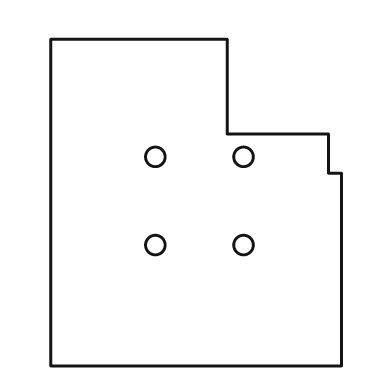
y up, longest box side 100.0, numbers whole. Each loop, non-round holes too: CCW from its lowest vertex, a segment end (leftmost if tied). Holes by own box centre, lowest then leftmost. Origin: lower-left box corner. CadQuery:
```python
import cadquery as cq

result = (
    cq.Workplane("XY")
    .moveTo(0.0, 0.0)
    .lineTo(89.0, 0.0)
    .lineTo(89.0, 59.0)
    .lineTo(85.0, 59.0)
    .lineTo(85.0, 71.0)
    .lineTo(54.0, 71.0)
    .lineTo(54.0, 100.0)
    .lineTo(0.0, 100.0)
    .close()
    .moveTo(32.0, 37.0)
    .circle(3.0)
    .moveTo(59.0, 37.0)
    .circle(3.0)
    .moveTo(32.0, 64.0)
    .circle(3.0)
    .moveTo(59.0, 64.0)
    .circle(3.0)
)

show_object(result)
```